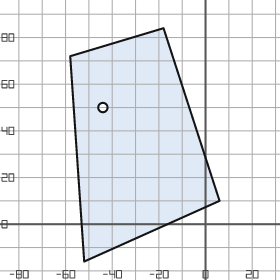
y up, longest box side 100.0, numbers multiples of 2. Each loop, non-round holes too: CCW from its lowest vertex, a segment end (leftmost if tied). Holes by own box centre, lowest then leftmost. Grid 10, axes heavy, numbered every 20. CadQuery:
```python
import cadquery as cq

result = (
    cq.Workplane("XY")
    .moveTo(-52.0, -16.0)
    .lineTo(6.0, 10.0)
    .lineTo(-18.0, 84.0)
    .lineTo(-58.0, 72.0)
    .close()
    .moveTo(-44.0, 50.0)
    .circle(2.0)
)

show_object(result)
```